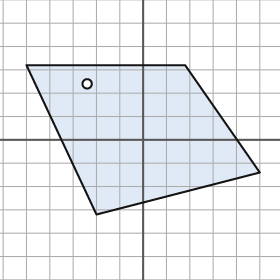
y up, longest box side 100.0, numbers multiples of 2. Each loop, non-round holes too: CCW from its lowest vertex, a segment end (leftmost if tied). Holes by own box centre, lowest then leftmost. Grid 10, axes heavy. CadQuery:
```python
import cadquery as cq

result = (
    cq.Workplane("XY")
    .moveTo(-20.0, -32.0)
    .lineTo(50.0, -14.0)
    .lineTo(18.0, 32.0)
    .lineTo(-50.0, 32.0)
    .close()
    .moveTo(-24.0, 24.0)
    .circle(2.0)
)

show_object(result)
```